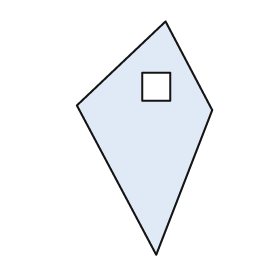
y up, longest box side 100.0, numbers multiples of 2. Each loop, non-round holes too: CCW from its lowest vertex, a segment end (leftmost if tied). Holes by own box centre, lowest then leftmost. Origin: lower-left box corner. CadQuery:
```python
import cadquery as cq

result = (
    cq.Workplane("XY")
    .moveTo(34.0, 0.0)
    .lineTo(58.0, 62.0)
    .lineTo(38.0, 100.0)
    .lineTo(0.0, 64.0)
    .close()
    .moveTo(28.0, 66.0)
    .lineTo(40.0, 66.0)
    .lineTo(40.0, 78.0)
    .lineTo(28.0, 78.0)
    .close()
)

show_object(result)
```